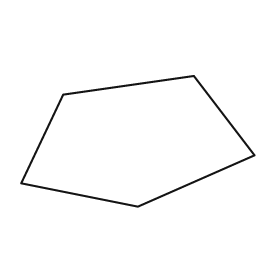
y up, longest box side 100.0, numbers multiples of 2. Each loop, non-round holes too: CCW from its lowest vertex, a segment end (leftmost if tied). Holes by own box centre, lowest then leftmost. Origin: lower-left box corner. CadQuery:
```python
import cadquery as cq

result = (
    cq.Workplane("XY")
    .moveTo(50.0, 0.0)
    .lineTo(100.0, 22.0)
    .lineTo(74.0, 56.0)
    .lineTo(18.0, 48.0)
    .lineTo(0.0, 10.0)
    .close()
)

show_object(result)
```